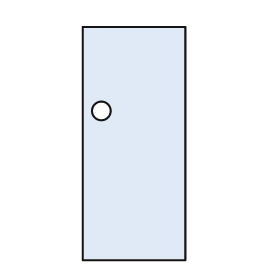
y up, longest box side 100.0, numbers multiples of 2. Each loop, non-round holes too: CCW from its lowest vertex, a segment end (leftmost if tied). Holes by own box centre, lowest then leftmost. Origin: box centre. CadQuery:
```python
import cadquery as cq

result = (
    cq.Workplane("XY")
    .moveTo(-22.0, -50.0)
    .lineTo(22.0, -50.0)
    .lineTo(22.0, 50.0)
    .lineTo(-22.0, 50.0)
    .close()
    .moveTo(-14.0, 14.0)
    .circle(4.0)
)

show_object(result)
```